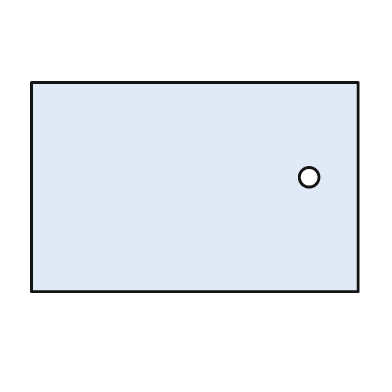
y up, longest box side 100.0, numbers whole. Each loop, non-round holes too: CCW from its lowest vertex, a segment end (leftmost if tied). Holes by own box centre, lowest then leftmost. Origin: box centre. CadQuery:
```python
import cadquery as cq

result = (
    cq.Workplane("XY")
    .moveTo(-50.0, -32.0)
    .lineTo(50.0, -32.0)
    .lineTo(50.0, 32.0)
    .lineTo(-50.0, 32.0)
    .close()
    .moveTo(35.0, 3.0)
    .circle(3.0)
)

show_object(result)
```